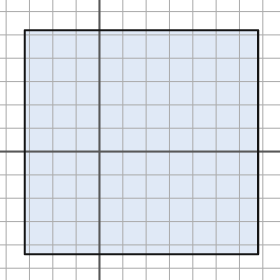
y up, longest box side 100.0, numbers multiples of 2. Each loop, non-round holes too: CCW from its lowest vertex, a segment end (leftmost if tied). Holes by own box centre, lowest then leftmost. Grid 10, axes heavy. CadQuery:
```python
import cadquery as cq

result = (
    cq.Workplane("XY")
    .moveTo(-32.0, -44.0)
    .lineTo(68.0, -44.0)
    .lineTo(68.0, 52.0)
    .lineTo(-32.0, 52.0)
    .close()
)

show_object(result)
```